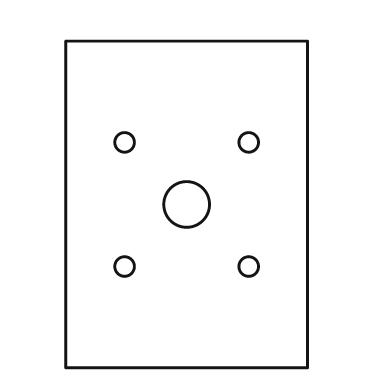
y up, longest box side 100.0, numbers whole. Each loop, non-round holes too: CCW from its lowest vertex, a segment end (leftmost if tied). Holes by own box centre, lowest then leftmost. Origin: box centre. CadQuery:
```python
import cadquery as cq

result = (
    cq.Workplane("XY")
    .moveTo(-37.0, -50.0)
    .lineTo(37.0, -50.0)
    .lineTo(37.0, 50.0)
    .lineTo(-37.0, 50.0)
    .close()
    .moveTo(-19.0, -19.0)
    .circle(3.0)
    .moveTo(19.0, -19.0)
    .circle(3.0)
    .moveTo(0.0, 0.0)
    .circle(7.0)
    .moveTo(-19.0, 19.0)
    .circle(3.0)
    .moveTo(19.0, 19.0)
    .circle(3.0)
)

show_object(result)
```